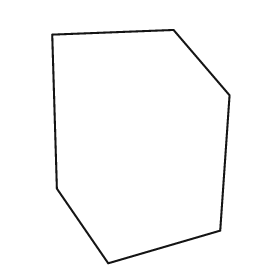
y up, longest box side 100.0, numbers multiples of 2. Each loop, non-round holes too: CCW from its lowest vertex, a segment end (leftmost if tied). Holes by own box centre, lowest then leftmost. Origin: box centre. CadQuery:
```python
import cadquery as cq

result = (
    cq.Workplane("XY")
    .moveTo(-14.0, -50.0)
    .lineTo(34.0, -36.0)
    .lineTo(38.0, 22.0)
    .lineTo(14.0, 50.0)
    .lineTo(-38.0, 48.0)
    .lineTo(-36.0, -18.0)
    .close()
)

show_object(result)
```